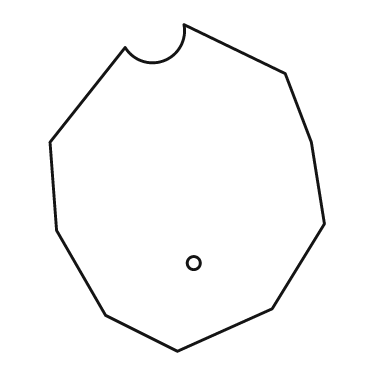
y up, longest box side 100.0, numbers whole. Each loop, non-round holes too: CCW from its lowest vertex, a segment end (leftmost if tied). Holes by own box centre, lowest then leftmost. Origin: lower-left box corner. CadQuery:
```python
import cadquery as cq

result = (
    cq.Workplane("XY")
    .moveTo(39.0, 0.0)
    .lineTo(68.0, 13.0)
    .lineTo(84.0, 39.0)
    .lineTo(80.0, 64.0)
    .lineTo(72.0, 85.0)
    .lineTo(41.0, 100.0)
    .threePointArc((35.0, 89.0), (23.0, 93.0))
    .lineTo(0.0, 64.0)
    .lineTo(2.0, 37.0)
    .lineTo(17.0, 11.0)
    .close()
    .moveTo(44.0, 27.0)
    .circle(2.0)
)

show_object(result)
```